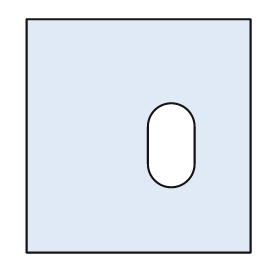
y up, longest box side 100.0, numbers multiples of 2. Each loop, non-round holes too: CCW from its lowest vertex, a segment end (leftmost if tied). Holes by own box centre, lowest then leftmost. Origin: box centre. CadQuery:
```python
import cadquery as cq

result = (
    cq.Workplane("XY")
    .moveTo(-48.0, -50.0)
    .lineTo(48.0, -50.0)
    .lineTo(48.0, 50.0)
    .lineTo(-48.0, 50.0)
    .close()
    .moveTo(4.0, -12.0)
    .threePointArc((14.0, -22.0), (24.0, -12.0))
    .lineTo(24.0, 4.0)
    .threePointArc((14.0, 14.0), (4.0, 4.0))
    .close()
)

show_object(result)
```